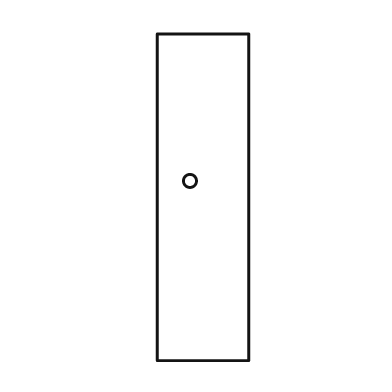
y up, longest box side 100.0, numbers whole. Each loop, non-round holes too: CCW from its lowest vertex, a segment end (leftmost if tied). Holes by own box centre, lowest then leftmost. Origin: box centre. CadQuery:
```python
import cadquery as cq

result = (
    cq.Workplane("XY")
    .moveTo(-14.0, -50.0)
    .lineTo(14.0, -50.0)
    .lineTo(14.0, 50.0)
    .lineTo(-14.0, 50.0)
    .close()
    .moveTo(-4.0, 5.0)
    .circle(2.0)
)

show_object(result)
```